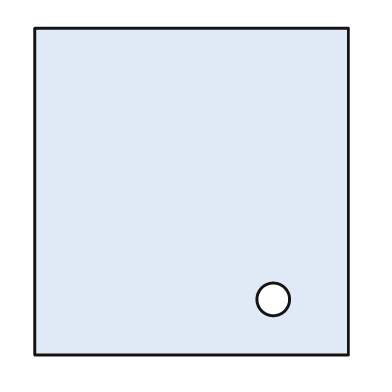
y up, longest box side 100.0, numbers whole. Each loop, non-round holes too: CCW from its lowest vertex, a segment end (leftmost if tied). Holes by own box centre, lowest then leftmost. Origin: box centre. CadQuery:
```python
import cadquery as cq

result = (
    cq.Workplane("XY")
    .moveTo(-48.0, -50.0)
    .lineTo(48.0, -50.0)
    .lineTo(48.0, 50.0)
    .lineTo(-48.0, 50.0)
    .close()
    .moveTo(25.0, -33.0)
    .circle(5.0)
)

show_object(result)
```